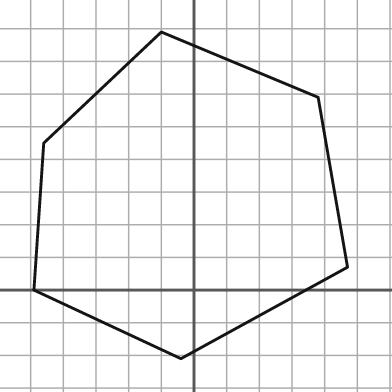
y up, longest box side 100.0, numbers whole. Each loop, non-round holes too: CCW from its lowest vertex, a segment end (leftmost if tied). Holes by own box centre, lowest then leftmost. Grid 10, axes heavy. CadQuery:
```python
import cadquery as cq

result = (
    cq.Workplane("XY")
    .moveTo(-4.0, -21.0)
    .lineTo(47.0, 7.0)
    .lineTo(38.0, 59.0)
    .lineTo(-10.0, 79.0)
    .lineTo(-46.0, 45.0)
    .lineTo(-49.0, 0.0)
    .close()
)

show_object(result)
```